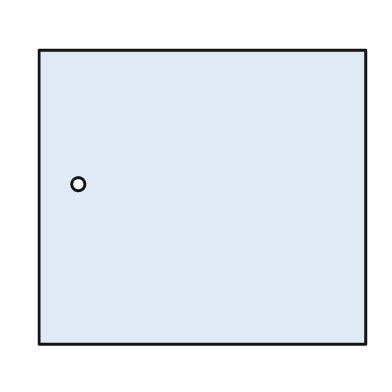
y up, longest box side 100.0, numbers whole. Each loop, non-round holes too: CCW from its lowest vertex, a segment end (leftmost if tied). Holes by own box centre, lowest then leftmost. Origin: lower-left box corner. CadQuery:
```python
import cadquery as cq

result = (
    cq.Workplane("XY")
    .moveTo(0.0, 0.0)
    .lineTo(100.0, 0.0)
    .lineTo(100.0, 90.0)
    .lineTo(0.0, 90.0)
    .close()
    .moveTo(12.0, 49.0)
    .circle(2.0)
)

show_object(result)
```